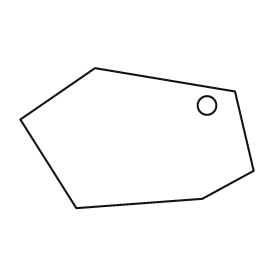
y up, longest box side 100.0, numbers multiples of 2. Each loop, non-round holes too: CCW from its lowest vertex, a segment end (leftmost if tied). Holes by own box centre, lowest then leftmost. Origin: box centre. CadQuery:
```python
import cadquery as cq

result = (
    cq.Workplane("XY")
    .moveTo(-26.0, -30.0)
    .lineTo(28.0, -26.0)
    .lineTo(50.0, -14.0)
    .lineTo(42.0, 20.0)
    .lineTo(-18.0, 30.0)
    .lineTo(-50.0, 8.0)
    .close()
    .moveTo(30.0, 14.0)
    .circle(4.0)
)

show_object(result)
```